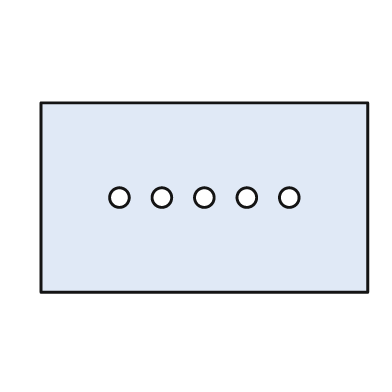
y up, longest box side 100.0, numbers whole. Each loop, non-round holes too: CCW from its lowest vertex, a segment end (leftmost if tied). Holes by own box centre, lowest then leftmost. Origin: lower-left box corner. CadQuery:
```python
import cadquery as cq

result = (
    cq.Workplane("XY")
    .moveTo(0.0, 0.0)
    .lineTo(100.0, 0.0)
    .lineTo(100.0, 58.0)
    .lineTo(0.0, 58.0)
    .close()
    .moveTo(24.0, 29.0)
    .circle(3.0)
    .moveTo(37.0, 29.0)
    .circle(3.0)
    .moveTo(50.0, 29.0)
    .circle(3.0)
    .moveTo(63.0, 29.0)
    .circle(3.0)
    .moveTo(76.0, 29.0)
    .circle(3.0)
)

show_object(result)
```